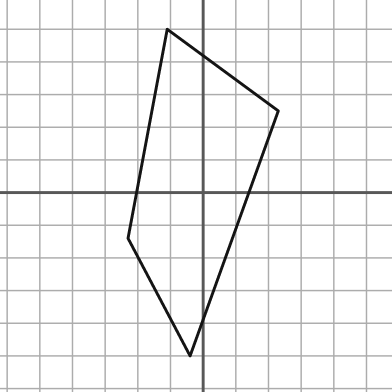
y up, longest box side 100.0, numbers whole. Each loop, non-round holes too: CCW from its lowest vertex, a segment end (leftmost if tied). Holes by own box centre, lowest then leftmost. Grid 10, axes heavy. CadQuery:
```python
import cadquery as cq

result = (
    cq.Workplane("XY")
    .moveTo(-4.0, -50.0)
    .lineTo(23.0, 25.0)
    .lineTo(-11.0, 50.0)
    .lineTo(-23.0, -14.0)
    .close()
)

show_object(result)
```